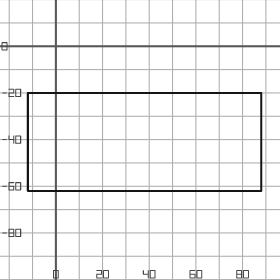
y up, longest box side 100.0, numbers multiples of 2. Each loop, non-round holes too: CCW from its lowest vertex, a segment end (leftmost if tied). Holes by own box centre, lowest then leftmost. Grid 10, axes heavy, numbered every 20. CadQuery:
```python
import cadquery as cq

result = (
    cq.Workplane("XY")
    .moveTo(-12.0, -62.0)
    .lineTo(88.0, -62.0)
    .lineTo(88.0, -20.0)
    .lineTo(-12.0, -20.0)
    .close()
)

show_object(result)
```